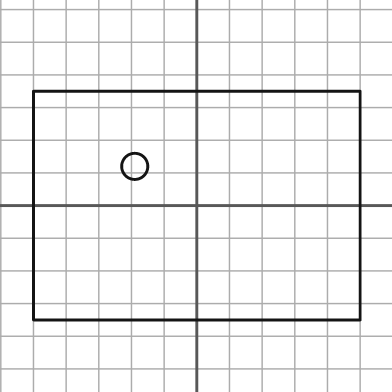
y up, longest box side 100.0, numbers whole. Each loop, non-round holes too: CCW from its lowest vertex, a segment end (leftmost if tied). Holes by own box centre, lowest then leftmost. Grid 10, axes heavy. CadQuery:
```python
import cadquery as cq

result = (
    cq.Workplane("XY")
    .moveTo(-50.0, -35.0)
    .lineTo(50.0, -35.0)
    .lineTo(50.0, 35.0)
    .lineTo(-50.0, 35.0)
    .close()
    .moveTo(-19.0, 12.0)
    .circle(4.0)
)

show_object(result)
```